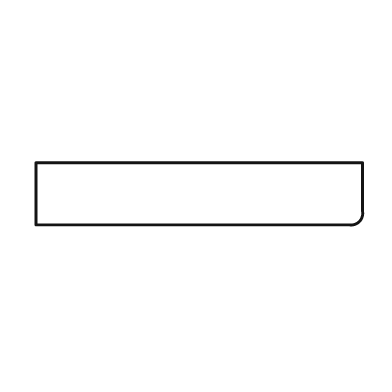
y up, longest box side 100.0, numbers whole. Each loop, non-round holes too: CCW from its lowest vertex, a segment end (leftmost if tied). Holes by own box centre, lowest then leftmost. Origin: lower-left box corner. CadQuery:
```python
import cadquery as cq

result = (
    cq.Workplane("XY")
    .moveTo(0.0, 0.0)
    .lineTo(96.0, 0.0)
    .threePointArc((99.0, 1.0), (100.0, 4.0))
    .lineTo(100.0, 19.0)
    .lineTo(0.0, 19.0)
    .close()
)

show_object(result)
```